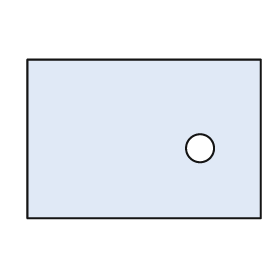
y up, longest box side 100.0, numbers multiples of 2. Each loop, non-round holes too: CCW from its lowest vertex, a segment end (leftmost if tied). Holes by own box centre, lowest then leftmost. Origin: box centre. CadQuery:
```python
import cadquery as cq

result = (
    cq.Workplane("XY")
    .moveTo(-50.0, -34.0)
    .lineTo(50.0, -34.0)
    .lineTo(50.0, 34.0)
    .lineTo(-50.0, 34.0)
    .close()
    .moveTo(24.0, -4.0)
    .circle(6.0)
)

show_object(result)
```